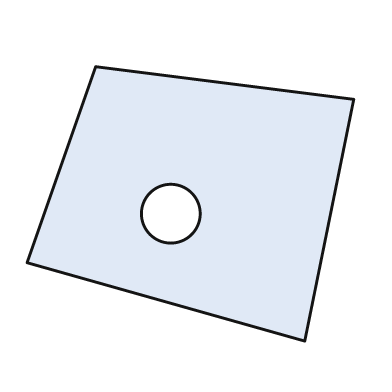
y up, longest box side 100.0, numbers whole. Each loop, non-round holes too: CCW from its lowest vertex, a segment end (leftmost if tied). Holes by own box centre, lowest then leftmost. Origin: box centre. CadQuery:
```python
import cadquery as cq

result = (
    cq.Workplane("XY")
    .moveTo(35.0, -42.0)
    .lineTo(50.0, 32.0)
    .lineTo(-29.0, 42.0)
    .lineTo(-50.0, -18.0)
    .close()
    .moveTo(-6.0, -3.0)
    .circle(9.0)
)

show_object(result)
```